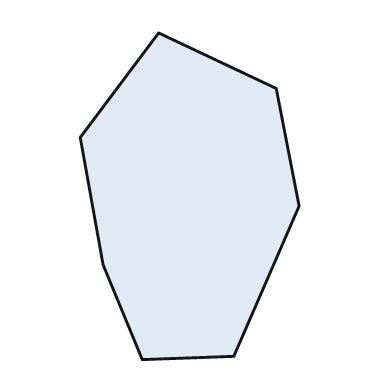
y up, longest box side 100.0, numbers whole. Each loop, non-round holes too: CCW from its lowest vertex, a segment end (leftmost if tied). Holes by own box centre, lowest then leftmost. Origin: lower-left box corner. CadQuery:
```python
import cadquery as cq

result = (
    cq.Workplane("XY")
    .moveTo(19.0, 0.0)
    .lineTo(47.0, 1.0)
    .lineTo(67.0, 47.0)
    .lineTo(60.0, 83.0)
    .lineTo(24.0, 100.0)
    .lineTo(0.0, 68.0)
    .lineTo(7.0, 29.0)
    .close()
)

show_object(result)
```